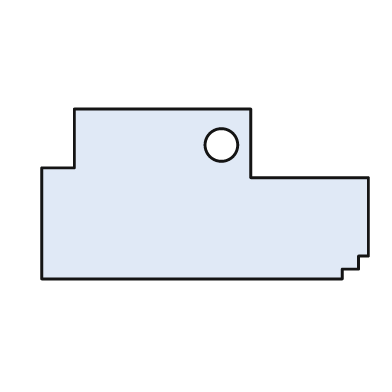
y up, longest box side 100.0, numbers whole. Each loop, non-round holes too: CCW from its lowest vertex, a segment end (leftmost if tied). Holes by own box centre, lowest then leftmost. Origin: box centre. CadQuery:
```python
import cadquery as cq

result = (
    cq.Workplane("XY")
    .moveTo(-50.0, -26.0)
    .lineTo(42.0, -26.0)
    .lineTo(42.0, -23.0)
    .lineTo(47.0, -23.0)
    .lineTo(47.0, -19.0)
    .lineTo(50.0, -19.0)
    .lineTo(50.0, 5.0)
    .lineTo(14.0, 5.0)
    .lineTo(14.0, 26.0)
    .lineTo(-40.0, 26.0)
    .lineTo(-40.0, 8.0)
    .lineTo(-50.0, 8.0)
    .close()
    .moveTo(5.0, 15.0)
    .circle(5.0)
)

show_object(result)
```